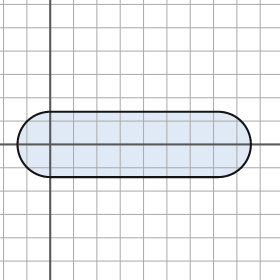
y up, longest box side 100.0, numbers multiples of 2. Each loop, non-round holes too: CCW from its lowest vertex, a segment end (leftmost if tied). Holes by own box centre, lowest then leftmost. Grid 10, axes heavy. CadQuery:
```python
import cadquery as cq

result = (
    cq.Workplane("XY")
    .moveTo(0.0, -14.0)
    .lineTo(72.0, -14.0)
    .threePointArc((86.0, 0.0), (72.0, 14.0))
    .lineTo(0.0, 14.0)
    .threePointArc((-14.0, 0.0), (0.0, -14.0))
    .close()
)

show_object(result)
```